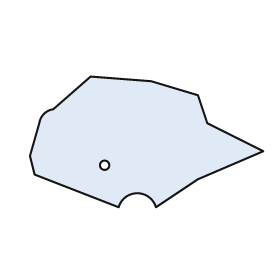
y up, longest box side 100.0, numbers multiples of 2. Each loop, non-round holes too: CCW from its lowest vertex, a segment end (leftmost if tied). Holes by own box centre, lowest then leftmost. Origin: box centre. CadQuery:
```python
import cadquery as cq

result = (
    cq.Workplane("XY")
    .moveTo(-12.0, -28.0)
    .threePointArc((-4.0, -22.0), (4.0, -28.0))
    .lineTo(22.0, -16.0)
    .lineTo(50.0, -4.0)
    .lineTo(26.0, 8.0)
    .lineTo(22.0, 20.0)
    .lineTo(2.0, 26.0)
    .lineTo(-24.0, 28.0)
    .lineTo(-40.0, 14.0)
    .threePointArc((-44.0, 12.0), (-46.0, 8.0))
    .lineTo(-50.0, -6.0)
    .lineTo(-48.0, -14.0)
    .close()
    .moveTo(-18.0, -10.0)
    .circle(2.0)
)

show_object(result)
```